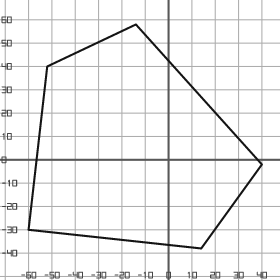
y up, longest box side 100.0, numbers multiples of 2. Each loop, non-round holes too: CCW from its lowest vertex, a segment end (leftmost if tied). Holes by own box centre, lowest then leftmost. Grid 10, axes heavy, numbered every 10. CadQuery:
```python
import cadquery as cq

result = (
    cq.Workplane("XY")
    .moveTo(14.0, -38.0)
    .lineTo(40.0, -2.0)
    .lineTo(-14.0, 58.0)
    .lineTo(-52.0, 40.0)
    .lineTo(-60.0, -30.0)
    .close()
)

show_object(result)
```